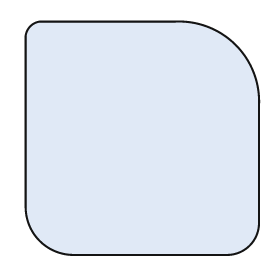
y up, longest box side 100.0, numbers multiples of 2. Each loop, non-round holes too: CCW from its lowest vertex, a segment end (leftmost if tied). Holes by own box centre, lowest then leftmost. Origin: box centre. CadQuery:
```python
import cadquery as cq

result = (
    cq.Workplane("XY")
    .moveTo(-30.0, -50.0)
    .lineTo(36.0, -50.0)
    .threePointArc((46.0, -46.0), (50.0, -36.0))
    .lineTo(50.0, 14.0)
    .threePointArc((40.0, 40.0), (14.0, 50.0))
    .lineTo(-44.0, 50.0)
    .threePointArc((-48.0, 48.0), (-50.0, 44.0))
    .lineTo(-50.0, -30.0)
    .threePointArc((-44.0, -44.0), (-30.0, -50.0))
    .close()
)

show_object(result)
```